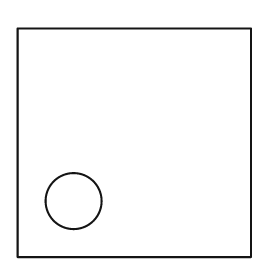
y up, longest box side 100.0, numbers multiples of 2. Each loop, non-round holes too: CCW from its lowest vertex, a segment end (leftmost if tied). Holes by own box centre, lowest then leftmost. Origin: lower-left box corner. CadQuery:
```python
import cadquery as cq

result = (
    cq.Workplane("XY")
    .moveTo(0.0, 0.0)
    .lineTo(100.0, 0.0)
    .lineTo(100.0, 98.0)
    .lineTo(0.0, 98.0)
    .close()
    .moveTo(24.0, 24.0)
    .circle(12.0)
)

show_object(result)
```